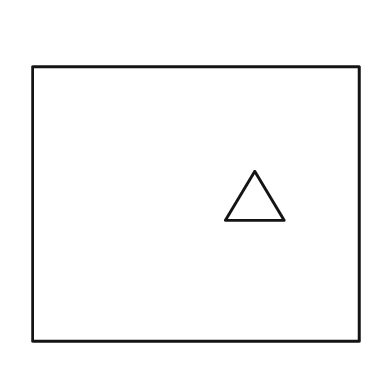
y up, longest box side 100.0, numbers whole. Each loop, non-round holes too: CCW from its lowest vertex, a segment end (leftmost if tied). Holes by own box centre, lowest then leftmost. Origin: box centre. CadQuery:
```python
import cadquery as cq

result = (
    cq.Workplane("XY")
    .moveTo(-50.0, -42.0)
    .lineTo(50.0, -42.0)
    .lineTo(50.0, 42.0)
    .lineTo(-50.0, 42.0)
    .close()
    .moveTo(9.0, -5.0)
    .lineTo(27.0, -5.0)
    .lineTo(18.0, 10.0)
    .close()
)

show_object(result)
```